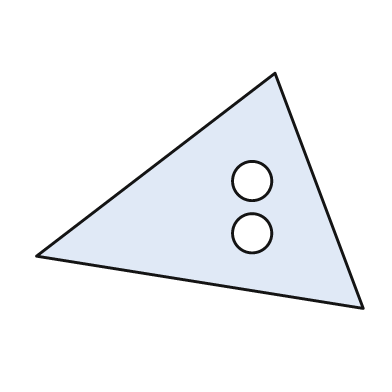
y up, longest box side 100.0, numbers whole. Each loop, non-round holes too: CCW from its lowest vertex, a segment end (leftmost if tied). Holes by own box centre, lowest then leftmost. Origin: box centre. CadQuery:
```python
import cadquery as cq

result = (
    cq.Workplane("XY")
    .moveTo(50.0, -36.0)
    .lineTo(23.0, 36.0)
    .lineTo(-50.0, -20.0)
    .close()
    .moveTo(16.0, -13.0)
    .circle(6.0)
    .moveTo(16.0, 3.0)
    .circle(6.0)
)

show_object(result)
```